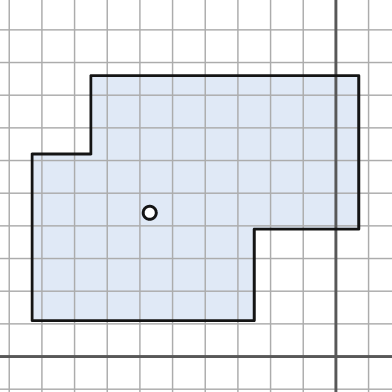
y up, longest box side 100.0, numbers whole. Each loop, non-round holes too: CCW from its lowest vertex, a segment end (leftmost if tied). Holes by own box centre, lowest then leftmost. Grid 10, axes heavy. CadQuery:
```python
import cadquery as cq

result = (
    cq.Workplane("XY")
    .moveTo(-93.0, 11.0)
    .lineTo(-25.0, 11.0)
    .lineTo(-25.0, 39.0)
    .lineTo(7.0, 39.0)
    .lineTo(7.0, 86.0)
    .lineTo(-75.0, 86.0)
    .lineTo(-75.0, 62.0)
    .lineTo(-93.0, 62.0)
    .close()
    .moveTo(-57.0, 44.0)
    .circle(2.0)
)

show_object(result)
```